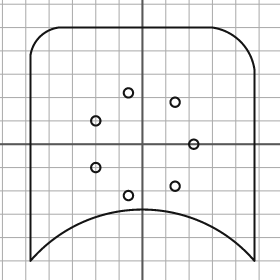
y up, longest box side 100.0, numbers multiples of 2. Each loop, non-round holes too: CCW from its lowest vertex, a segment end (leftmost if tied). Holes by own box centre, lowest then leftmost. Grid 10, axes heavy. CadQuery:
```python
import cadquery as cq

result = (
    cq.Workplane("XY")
    .moveTo(-48.0, -50.0)
    .threePointArc((0.0, -28.0), (48.0, -50.0))
    .lineTo(48.0, 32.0)
    .threePointArc((42.0, 44.0), (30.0, 50.0))
    .lineTo(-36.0, 50.0)
    .threePointArc((-44.0, 46.0), (-48.0, 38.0))
    .close()
    .moveTo(-6.0, -22.0)
    .circle(2.0)
    .moveTo(14.0, -18.0)
    .circle(2.0)
    .moveTo(-20.0, -10.0)
    .circle(2.0)
    .moveTo(22.0, 0.0)
    .circle(2.0)
    .moveTo(-20.0, 10.0)
    .circle(2.0)
    .moveTo(14.0, 18.0)
    .circle(2.0)
    .moveTo(-6.0, 22.0)
    .circle(2.0)
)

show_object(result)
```